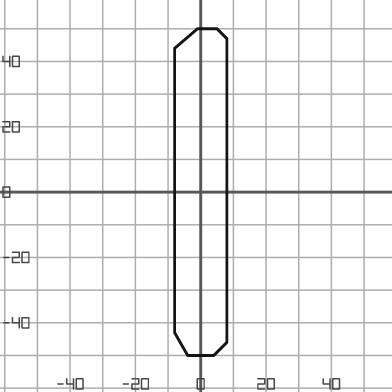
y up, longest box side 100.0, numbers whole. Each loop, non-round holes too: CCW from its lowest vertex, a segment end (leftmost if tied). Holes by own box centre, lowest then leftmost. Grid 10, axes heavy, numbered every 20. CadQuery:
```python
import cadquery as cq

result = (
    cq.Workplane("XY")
    .moveTo(-4.0, -50.0)
    .lineTo(4.0, -50.0)
    .lineTo(8.0, -46.0)
    .lineTo(8.0, 47.0)
    .lineTo(5.0, 50.0)
    .lineTo(-1.0, 50.0)
    .lineTo(-8.0, 44.0)
    .lineTo(-8.0, -43.0)
    .close()
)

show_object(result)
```